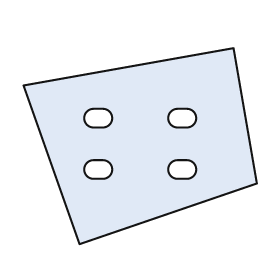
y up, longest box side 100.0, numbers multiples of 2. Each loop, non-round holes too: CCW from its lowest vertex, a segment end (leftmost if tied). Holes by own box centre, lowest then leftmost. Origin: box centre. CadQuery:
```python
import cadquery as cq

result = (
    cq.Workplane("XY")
    .moveTo(-26.0, -42.0)
    .lineTo(50.0, -16.0)
    .lineTo(40.0, 42.0)
    .lineTo(-50.0, 26.0)
    .close()
    .moveTo(-20.0, -14.0)
    .lineTo(-16.0, -14.0)
    .threePointArc((-12.0, -10.0), (-16.0, -6.0))
    .lineTo(-20.0, -6.0)
    .threePointArc((-24.0, -10.0), (-20.0, -14.0))
    .close()
    .moveTo(16.0, -14.0)
    .lineTo(20.0, -14.0)
    .threePointArc((24.0, -10.0), (20.0, -6.0))
    .lineTo(16.0, -6.0)
    .threePointArc((12.0, -10.0), (16.0, -14.0))
    .close()
    .moveTo(-20.0, 8.0)
    .lineTo(-16.0, 8.0)
    .threePointArc((-12.0, 12.0), (-16.0, 16.0))
    .lineTo(-20.0, 16.0)
    .threePointArc((-24.0, 12.0), (-20.0, 8.0))
    .close()
    .moveTo(16.0, 8.0)
    .lineTo(20.0, 8.0)
    .threePointArc((24.0, 12.0), (20.0, 16.0))
    .lineTo(16.0, 16.0)
    .threePointArc((12.0, 12.0), (16.0, 8.0))
    .close()
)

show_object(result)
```